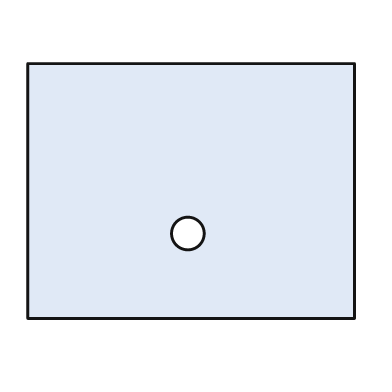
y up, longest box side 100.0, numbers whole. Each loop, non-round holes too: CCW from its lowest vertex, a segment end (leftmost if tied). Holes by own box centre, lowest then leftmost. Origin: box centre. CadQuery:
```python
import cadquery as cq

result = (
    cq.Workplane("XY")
    .moveTo(-50.0, -39.0)
    .lineTo(50.0, -39.0)
    .lineTo(50.0, 39.0)
    .lineTo(-50.0, 39.0)
    .close()
    .moveTo(-1.0, -13.0)
    .circle(5.0)
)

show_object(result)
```